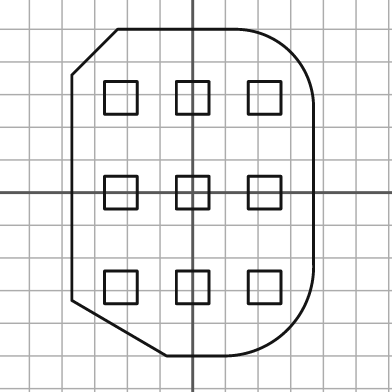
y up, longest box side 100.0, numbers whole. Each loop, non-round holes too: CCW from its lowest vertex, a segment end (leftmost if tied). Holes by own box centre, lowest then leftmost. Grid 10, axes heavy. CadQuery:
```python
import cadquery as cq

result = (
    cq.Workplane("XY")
    .moveTo(-8.0, -50.0)
    .lineTo(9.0, -50.0)
    .threePointArc((29.0, -42.0), (37.0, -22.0))
    .lineTo(37.0, 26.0)
    .threePointArc((30.0, 43.0), (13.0, 50.0))
    .lineTo(-23.0, 50.0)
    .lineTo(-37.0, 36.0)
    .lineTo(-37.0, -33.0)
    .close()
    .moveTo(-27.0, -34.0)
    .lineTo(-17.0, -34.0)
    .lineTo(-17.0, -24.0)
    .lineTo(-27.0, -24.0)
    .close()
    .moveTo(-5.0, -34.0)
    .lineTo(5.0, -34.0)
    .lineTo(5.0, -24.0)
    .lineTo(-5.0, -24.0)
    .close()
    .moveTo(17.0, -34.0)
    .lineTo(27.0, -34.0)
    .lineTo(27.0, -24.0)
    .lineTo(17.0, -24.0)
    .close()
    .moveTo(-27.0, -5.0)
    .lineTo(-17.0, -5.0)
    .lineTo(-17.0, 5.0)
    .lineTo(-27.0, 5.0)
    .close()
    .moveTo(-5.0, -5.0)
    .lineTo(5.0, -5.0)
    .lineTo(5.0, 5.0)
    .lineTo(-5.0, 5.0)
    .close()
    .moveTo(17.0, -5.0)
    .lineTo(27.0, -5.0)
    .lineTo(27.0, 5.0)
    .lineTo(17.0, 5.0)
    .close()
    .moveTo(-27.0, 24.0)
    .lineTo(-17.0, 24.0)
    .lineTo(-17.0, 34.0)
    .lineTo(-27.0, 34.0)
    .close()
    .moveTo(-5.0, 24.0)
    .lineTo(5.0, 24.0)
    .lineTo(5.0, 34.0)
    .lineTo(-5.0, 34.0)
    .close()
    .moveTo(17.0, 24.0)
    .lineTo(27.0, 24.0)
    .lineTo(27.0, 34.0)
    .lineTo(17.0, 34.0)
    .close()
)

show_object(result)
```